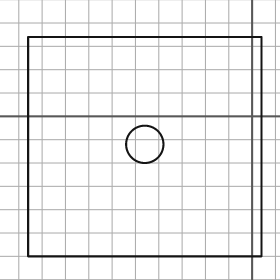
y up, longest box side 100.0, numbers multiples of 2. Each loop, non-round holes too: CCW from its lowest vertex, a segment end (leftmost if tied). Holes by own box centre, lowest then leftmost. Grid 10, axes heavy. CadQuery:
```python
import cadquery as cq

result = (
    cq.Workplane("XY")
    .moveTo(-96.0, -60.0)
    .lineTo(4.0, -60.0)
    .lineTo(4.0, 34.0)
    .lineTo(-96.0, 34.0)
    .close()
    .moveTo(-46.0, -12.0)
    .circle(8.0)
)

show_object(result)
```